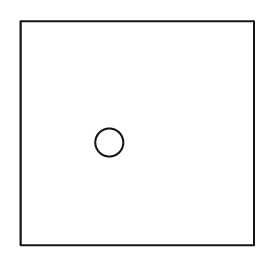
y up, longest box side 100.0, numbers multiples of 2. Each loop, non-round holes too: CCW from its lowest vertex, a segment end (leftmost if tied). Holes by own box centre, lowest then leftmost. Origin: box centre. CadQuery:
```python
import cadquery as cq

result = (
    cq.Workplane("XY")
    .moveTo(-50.0, -48.0)
    .lineTo(50.0, -48.0)
    .lineTo(50.0, 48.0)
    .lineTo(-50.0, 48.0)
    .close()
    .moveTo(-12.0, -4.0)
    .circle(6.0)
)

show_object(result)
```